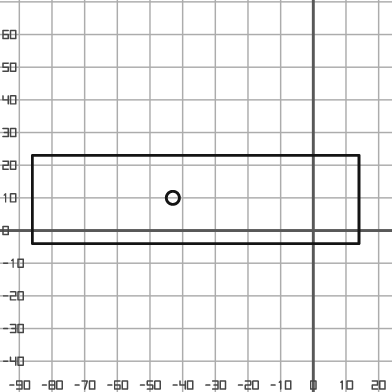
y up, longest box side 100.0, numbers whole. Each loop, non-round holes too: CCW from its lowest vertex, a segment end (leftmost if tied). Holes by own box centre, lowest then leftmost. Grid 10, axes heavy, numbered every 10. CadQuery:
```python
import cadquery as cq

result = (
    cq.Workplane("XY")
    .moveTo(-86.0, -4.0)
    .lineTo(14.0, -4.0)
    .lineTo(14.0, 23.0)
    .lineTo(-86.0, 23.0)
    .close()
    .moveTo(-43.0, 10.0)
    .circle(2.0)
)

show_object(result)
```